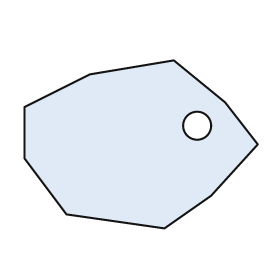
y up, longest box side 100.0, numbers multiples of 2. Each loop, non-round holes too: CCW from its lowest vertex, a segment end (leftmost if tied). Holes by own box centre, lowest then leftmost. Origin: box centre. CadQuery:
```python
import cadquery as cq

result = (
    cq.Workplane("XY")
    .moveTo(10.0, -36.0)
    .lineTo(30.0, -22.0)
    .lineTo(50.0, 0.0)
    .lineTo(36.0, 18.0)
    .lineTo(14.0, 36.0)
    .lineTo(-22.0, 30.0)
    .lineTo(-50.0, 16.0)
    .lineTo(-50.0, -6.0)
    .lineTo(-32.0, -30.0)
    .close()
    .moveTo(24.0, 8.0)
    .circle(6.0)
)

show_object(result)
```